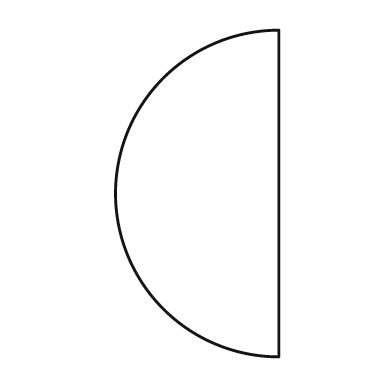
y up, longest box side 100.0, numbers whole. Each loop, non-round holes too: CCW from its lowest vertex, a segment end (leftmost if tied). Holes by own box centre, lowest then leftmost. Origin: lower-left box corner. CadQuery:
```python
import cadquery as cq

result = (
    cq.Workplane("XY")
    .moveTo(50.0, 0.0)
    .lineTo(50.0, 100.0)
    .threePointArc((0.0, 50.0), (50.0, 0.0))
    .close()
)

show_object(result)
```